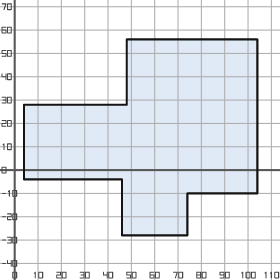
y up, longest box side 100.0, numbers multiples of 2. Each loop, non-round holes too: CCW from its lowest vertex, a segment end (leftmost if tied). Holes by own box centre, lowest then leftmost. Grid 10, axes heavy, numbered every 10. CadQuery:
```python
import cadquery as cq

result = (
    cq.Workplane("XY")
    .moveTo(46.0, -28.0)
    .lineTo(74.0, -28.0)
    .lineTo(74.0, -10.0)
    .lineTo(104.0, -10.0)
    .lineTo(104.0, 56.0)
    .lineTo(48.0, 56.0)
    .lineTo(48.0, 28.0)
    .lineTo(4.0, 28.0)
    .lineTo(4.0, -4.0)
    .lineTo(46.0, -4.0)
    .close()
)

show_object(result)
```